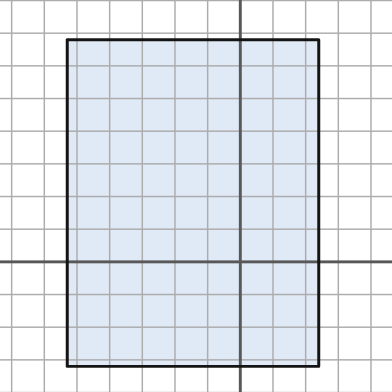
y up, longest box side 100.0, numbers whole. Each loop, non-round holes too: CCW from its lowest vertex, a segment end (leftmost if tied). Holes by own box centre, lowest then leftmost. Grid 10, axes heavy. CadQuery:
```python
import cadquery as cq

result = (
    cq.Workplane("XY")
    .moveTo(-53.0, -32.0)
    .lineTo(24.0, -32.0)
    .lineTo(24.0, 68.0)
    .lineTo(-53.0, 68.0)
    .close()
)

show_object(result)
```